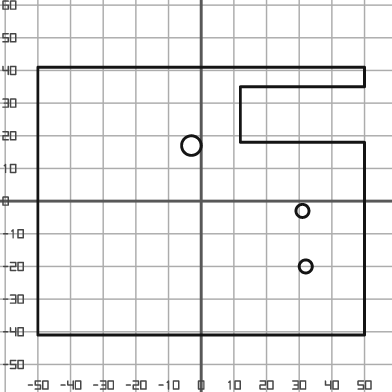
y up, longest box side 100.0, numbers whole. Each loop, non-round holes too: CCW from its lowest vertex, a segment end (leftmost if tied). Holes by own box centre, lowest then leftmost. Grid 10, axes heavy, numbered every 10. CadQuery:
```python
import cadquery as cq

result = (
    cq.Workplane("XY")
    .moveTo(-50.0, -41.0)
    .lineTo(50.0, -41.0)
    .lineTo(50.0, 18.0)
    .lineTo(12.0, 18.0)
    .lineTo(12.0, 35.0)
    .lineTo(50.0, 35.0)
    .lineTo(50.0, 41.0)
    .lineTo(-50.0, 41.0)
    .close()
    .moveTo(32.0, -20.0)
    .circle(2.0)
    .moveTo(31.0, -3.0)
    .circle(2.0)
    .moveTo(-3.0, 17.0)
    .circle(3.0)
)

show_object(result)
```